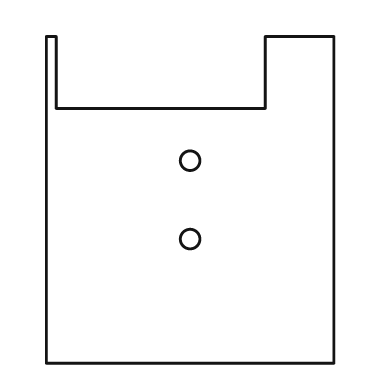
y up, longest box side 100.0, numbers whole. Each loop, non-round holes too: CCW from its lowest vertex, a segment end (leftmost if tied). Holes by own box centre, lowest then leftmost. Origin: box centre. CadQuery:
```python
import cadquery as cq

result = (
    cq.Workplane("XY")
    .moveTo(-44.0, -50.0)
    .lineTo(44.0, -50.0)
    .lineTo(44.0, 50.0)
    .lineTo(23.0, 50.0)
    .lineTo(23.0, 28.0)
    .lineTo(-41.0, 28.0)
    .lineTo(-41.0, 50.0)
    .lineTo(-44.0, 50.0)
    .close()
    .moveTo(0.0, -12.0)
    .circle(3.0)
    .moveTo(0.0, 12.0)
    .circle(3.0)
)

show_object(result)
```